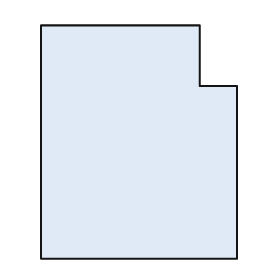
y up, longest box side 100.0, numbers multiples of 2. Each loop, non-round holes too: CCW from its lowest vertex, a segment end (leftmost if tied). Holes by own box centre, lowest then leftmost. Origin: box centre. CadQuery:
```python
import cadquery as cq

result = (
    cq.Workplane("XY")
    .moveTo(-42.0, -50.0)
    .lineTo(42.0, -50.0)
    .lineTo(42.0, 24.0)
    .lineTo(26.0, 24.0)
    .lineTo(26.0, 50.0)
    .lineTo(-42.0, 50.0)
    .close()
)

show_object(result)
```